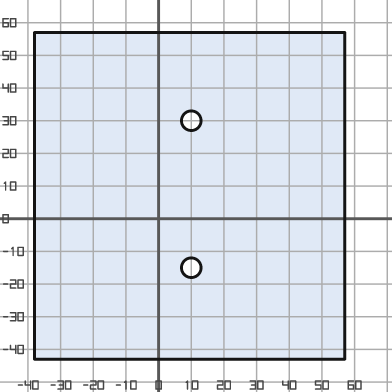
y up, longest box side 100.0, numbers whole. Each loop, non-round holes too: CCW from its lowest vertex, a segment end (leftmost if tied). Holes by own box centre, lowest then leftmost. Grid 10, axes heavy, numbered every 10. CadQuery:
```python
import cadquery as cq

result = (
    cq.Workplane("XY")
    .moveTo(-38.0, -43.0)
    .lineTo(57.0, -43.0)
    .lineTo(57.0, 57.0)
    .lineTo(-38.0, 57.0)
    .close()
    .moveTo(10.0, -15.0)
    .circle(3.0)
    .moveTo(10.0, 30.0)
    .circle(3.0)
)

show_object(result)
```